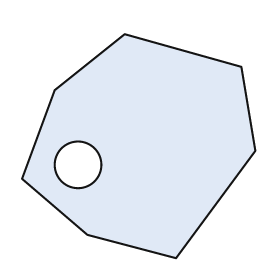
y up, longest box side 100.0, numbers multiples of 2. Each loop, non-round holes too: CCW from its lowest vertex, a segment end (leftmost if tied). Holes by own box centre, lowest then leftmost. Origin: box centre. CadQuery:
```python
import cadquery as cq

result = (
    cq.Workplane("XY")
    .moveTo(16.0, -48.0)
    .lineTo(50.0, -2.0)
    .lineTo(44.0, 34.0)
    .lineTo(-6.0, 48.0)
    .lineTo(-36.0, 24.0)
    .lineTo(-50.0, -14.0)
    .lineTo(-22.0, -38.0)
    .close()
    .moveTo(-26.0, -8.0)
    .circle(10.0)
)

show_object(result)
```